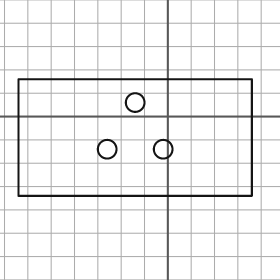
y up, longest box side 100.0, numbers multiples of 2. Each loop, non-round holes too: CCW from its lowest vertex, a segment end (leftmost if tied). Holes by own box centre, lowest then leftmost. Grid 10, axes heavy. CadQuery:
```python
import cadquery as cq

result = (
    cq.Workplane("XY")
    .moveTo(-64.0, -34.0)
    .lineTo(36.0, -34.0)
    .lineTo(36.0, 16.0)
    .lineTo(-64.0, 16.0)
    .close()
    .moveTo(-26.0, -14.0)
    .circle(4.0)
    .moveTo(-2.0, -14.0)
    .circle(4.0)
    .moveTo(-14.0, 6.0)
    .circle(4.0)
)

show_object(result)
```